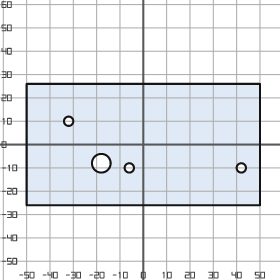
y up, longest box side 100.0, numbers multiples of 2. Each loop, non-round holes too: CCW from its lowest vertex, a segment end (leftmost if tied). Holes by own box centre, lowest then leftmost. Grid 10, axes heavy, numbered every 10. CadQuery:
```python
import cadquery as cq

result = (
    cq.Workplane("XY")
    .moveTo(-50.0, -26.0)
    .lineTo(50.0, -26.0)
    .lineTo(50.0, 26.0)
    .lineTo(-50.0, 26.0)
    .close()
    .moveTo(-6.0, -10.0)
    .circle(2.0)
    .moveTo(42.0, -10.0)
    .circle(2.0)
    .moveTo(-18.0, -8.0)
    .circle(4.0)
    .moveTo(-32.0, 10.0)
    .circle(2.0)
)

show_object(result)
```